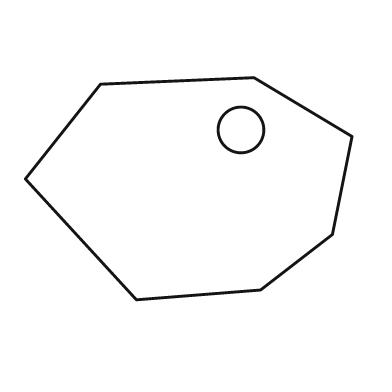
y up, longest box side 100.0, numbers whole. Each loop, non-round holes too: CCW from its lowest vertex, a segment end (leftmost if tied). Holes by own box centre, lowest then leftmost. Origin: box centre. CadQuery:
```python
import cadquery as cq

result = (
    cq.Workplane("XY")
    .moveTo(-16.0, -34.0)
    .lineTo(22.0, -31.0)
    .lineTo(44.0, -14.0)
    .lineTo(50.0, 16.0)
    .lineTo(20.0, 34.0)
    .lineTo(-27.0, 32.0)
    .lineTo(-50.0, 3.0)
    .close()
    .moveTo(16.0, 18.0)
    .circle(7.0)
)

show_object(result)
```